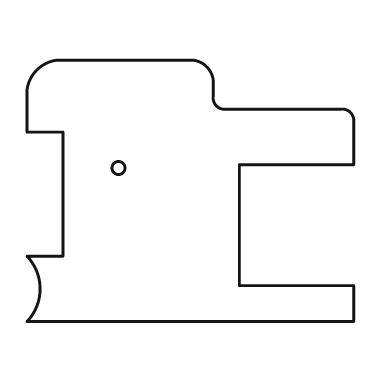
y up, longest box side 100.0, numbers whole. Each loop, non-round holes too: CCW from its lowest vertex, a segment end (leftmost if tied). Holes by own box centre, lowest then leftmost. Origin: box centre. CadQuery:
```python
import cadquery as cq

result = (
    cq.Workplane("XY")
    .moveTo(-50.0, -40.0)
    .lineTo(50.0, -40.0)
    .lineTo(50.0, -29.0)
    .lineTo(15.0, -29.0)
    .lineTo(15.0, 8.0)
    .lineTo(50.0, 8.0)
    .lineTo(50.0, 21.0)
    .threePointArc((49.0, 24.0), (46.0, 25.0))
    .lineTo(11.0, 25.0)
    .threePointArc((8.0, 26.0), (7.0, 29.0))
    .lineTo(7.0, 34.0)
    .threePointArc((5.0, 38.0), (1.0, 40.0))
    .lineTo(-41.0, 40.0)
    .threePointArc((-47.0, 37.0), (-50.0, 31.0))
    .lineTo(-50.0, 18.0)
    .lineTo(-39.0, 18.0)
    .lineTo(-39.0, -20.0)
    .lineTo(-50.0, -20.0)
    .threePointArc((-46.0, -30.0), (-50.0, -40.0))
    .close()
    .moveTo(-22.0, 7.0)
    .circle(2.0)
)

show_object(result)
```